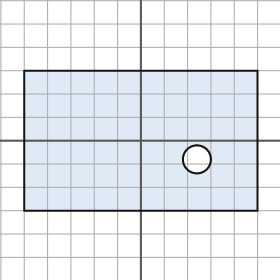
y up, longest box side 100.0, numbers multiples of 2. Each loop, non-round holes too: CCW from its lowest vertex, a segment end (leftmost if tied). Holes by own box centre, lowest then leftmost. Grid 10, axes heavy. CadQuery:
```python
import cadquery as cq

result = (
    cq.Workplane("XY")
    .moveTo(-50.0, -30.0)
    .lineTo(50.0, -30.0)
    .lineTo(50.0, 30.0)
    .lineTo(-50.0, 30.0)
    .close()
    .moveTo(24.0, -8.0)
    .circle(6.0)
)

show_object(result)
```